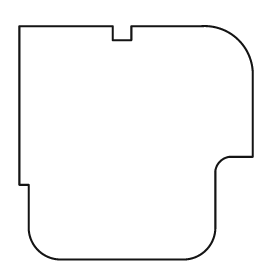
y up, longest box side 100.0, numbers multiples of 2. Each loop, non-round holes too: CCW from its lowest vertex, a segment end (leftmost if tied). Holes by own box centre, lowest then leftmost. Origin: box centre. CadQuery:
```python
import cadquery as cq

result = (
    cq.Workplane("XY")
    .moveTo(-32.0, -50.0)
    .lineTo(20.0, -50.0)
    .threePointArc((30.0, -46.0), (34.0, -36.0))
    .lineTo(34.0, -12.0)
    .threePointArc((36.0, -8.0), (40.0, -6.0))
    .lineTo(50.0, -6.0)
    .lineTo(50.0, 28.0)
    .threePointArc((44.0, 44.0), (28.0, 50.0))
    .lineTo(-2.0, 50.0)
    .lineTo(-2.0, 44.0)
    .lineTo(-10.0, 44.0)
    .lineTo(-10.0, 50.0)
    .lineTo(-50.0, 50.0)
    .lineTo(-50.0, -18.0)
    .lineTo(-46.0, -18.0)
    .lineTo(-46.0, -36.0)
    .threePointArc((-42.0, -46.0), (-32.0, -50.0))
    .close()
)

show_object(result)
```